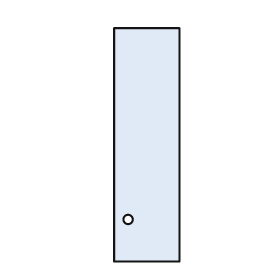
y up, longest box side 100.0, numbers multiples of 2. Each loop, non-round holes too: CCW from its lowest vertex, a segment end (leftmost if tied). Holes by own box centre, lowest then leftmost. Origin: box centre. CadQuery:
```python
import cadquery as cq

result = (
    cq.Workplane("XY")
    .moveTo(-14.0, -50.0)
    .lineTo(14.0, -50.0)
    .lineTo(14.0, 50.0)
    .lineTo(-14.0, 50.0)
    .close()
    .moveTo(-8.0, -32.0)
    .circle(2.0)
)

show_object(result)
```